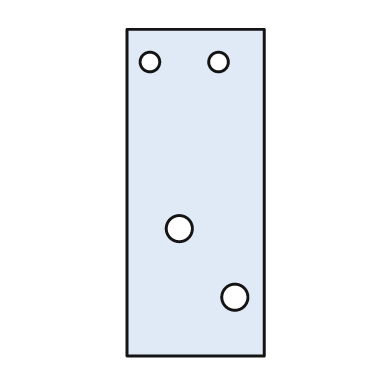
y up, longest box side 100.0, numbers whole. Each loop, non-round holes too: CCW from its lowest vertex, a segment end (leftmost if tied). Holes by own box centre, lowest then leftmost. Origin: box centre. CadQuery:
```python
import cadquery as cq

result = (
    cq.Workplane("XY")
    .moveTo(-21.0, -50.0)
    .lineTo(21.0, -50.0)
    .lineTo(21.0, 50.0)
    .lineTo(-21.0, 50.0)
    .close()
    .moveTo(12.0, -32.0)
    .circle(4.0)
    .moveTo(-5.0, -11.0)
    .circle(4.0)
    .moveTo(-14.0, 40.0)
    .circle(3.0)
    .moveTo(7.0, 40.0)
    .circle(3.0)
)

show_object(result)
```